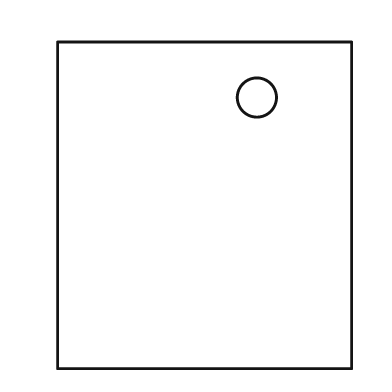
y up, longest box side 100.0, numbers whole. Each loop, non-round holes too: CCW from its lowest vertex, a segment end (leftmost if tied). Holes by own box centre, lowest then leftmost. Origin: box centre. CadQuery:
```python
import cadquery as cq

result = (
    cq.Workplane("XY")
    .moveTo(-45.0, -50.0)
    .lineTo(45.0, -50.0)
    .lineTo(45.0, 50.0)
    .lineTo(-45.0, 50.0)
    .close()
    .moveTo(16.0, 33.0)
    .circle(6.0)
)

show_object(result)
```